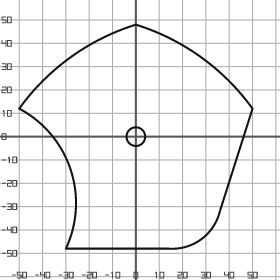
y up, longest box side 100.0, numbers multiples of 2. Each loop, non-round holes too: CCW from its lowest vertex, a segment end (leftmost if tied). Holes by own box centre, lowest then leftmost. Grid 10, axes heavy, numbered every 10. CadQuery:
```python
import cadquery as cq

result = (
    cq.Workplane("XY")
    .moveTo(-30.0, -48.0)
    .lineTo(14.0, -48.0)
    .threePointArc((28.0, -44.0), (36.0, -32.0))
    .lineTo(50.0, 12.0)
    .threePointArc((28.0, 34.0), (0.0, 48.0))
    .threePointArc((-28.0, 34.0), (-50.0, 12.0))
    .threePointArc((-28.0, -14.0), (-30.0, -48.0))
    .close()
    .moveTo(0.0, 0.0)
    .circle(4.0)
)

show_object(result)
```